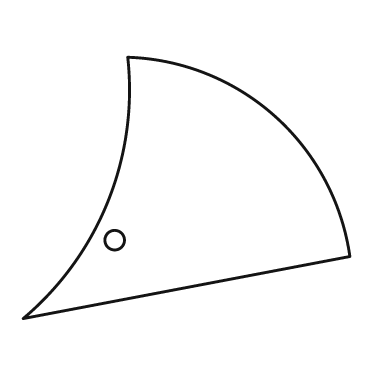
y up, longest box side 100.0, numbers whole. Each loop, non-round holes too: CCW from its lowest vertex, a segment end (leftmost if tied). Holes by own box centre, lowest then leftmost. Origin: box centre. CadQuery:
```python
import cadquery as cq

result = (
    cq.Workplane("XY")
    .moveTo(-50.0, -40.0)
    .lineTo(50.0, -21.0)
    .threePointArc((27.0, 22.0), (-18.0, 40.0))
    .threePointArc((-24.0, -4.0), (-50.0, -40.0))
    .close()
    .moveTo(-22.0, -16.0)
    .circle(3.0)
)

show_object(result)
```